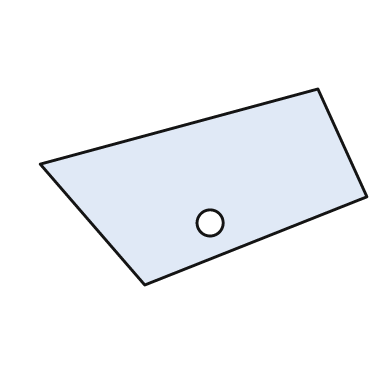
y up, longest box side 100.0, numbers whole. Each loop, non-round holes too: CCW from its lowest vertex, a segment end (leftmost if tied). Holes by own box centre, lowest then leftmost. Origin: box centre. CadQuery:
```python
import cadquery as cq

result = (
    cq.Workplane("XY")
    .moveTo(-18.0, -30.0)
    .lineTo(50.0, -3.0)
    .lineTo(35.0, 30.0)
    .lineTo(-50.0, 7.0)
    .close()
    .moveTo(2.0, -11.0)
    .circle(4.0)
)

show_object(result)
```